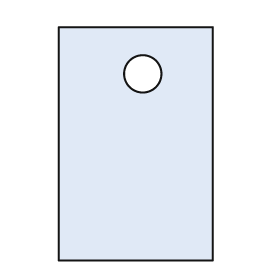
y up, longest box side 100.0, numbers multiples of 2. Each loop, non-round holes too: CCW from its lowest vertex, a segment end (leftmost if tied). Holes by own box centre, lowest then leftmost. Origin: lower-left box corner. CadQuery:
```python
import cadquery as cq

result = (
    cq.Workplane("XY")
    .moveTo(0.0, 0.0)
    .lineTo(66.0, 0.0)
    .lineTo(66.0, 100.0)
    .lineTo(0.0, 100.0)
    .close()
    .moveTo(36.0, 80.0)
    .circle(8.0)
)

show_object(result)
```